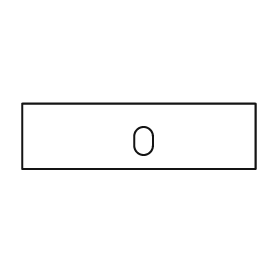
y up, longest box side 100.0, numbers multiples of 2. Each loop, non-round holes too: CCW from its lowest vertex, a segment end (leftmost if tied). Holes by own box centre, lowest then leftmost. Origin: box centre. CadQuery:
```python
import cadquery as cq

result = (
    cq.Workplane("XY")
    .moveTo(-50.0, -14.0)
    .lineTo(50.0, -14.0)
    .lineTo(50.0, 14.0)
    .lineTo(-50.0, 14.0)
    .close()
    .moveTo(-2.0, -4.0)
    .threePointArc((2.0, -8.0), (6.0, -4.0))
    .lineTo(6.0, 0.0)
    .threePointArc((2.0, 4.0), (-2.0, 0.0))
    .close()
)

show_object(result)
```